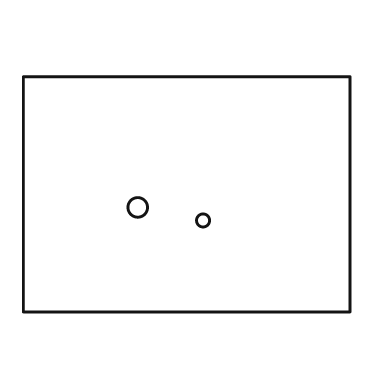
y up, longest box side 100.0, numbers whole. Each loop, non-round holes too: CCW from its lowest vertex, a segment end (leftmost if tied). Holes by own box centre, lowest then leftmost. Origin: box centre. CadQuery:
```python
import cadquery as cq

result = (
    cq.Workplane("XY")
    .moveTo(-50.0, -36.0)
    .lineTo(50.0, -36.0)
    .lineTo(50.0, 36.0)
    .lineTo(-50.0, 36.0)
    .close()
    .moveTo(5.0, -8.0)
    .circle(2.0)
    .moveTo(-15.0, -4.0)
    .circle(3.0)
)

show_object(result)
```